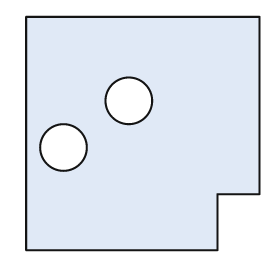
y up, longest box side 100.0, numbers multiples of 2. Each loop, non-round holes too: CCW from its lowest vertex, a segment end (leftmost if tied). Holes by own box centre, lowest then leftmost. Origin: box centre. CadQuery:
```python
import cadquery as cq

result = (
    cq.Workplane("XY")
    .moveTo(-50.0, -50.0)
    .lineTo(32.0, -50.0)
    .lineTo(32.0, -26.0)
    .lineTo(50.0, -26.0)
    .lineTo(50.0, 50.0)
    .lineTo(-50.0, 50.0)
    .close()
    .moveTo(-34.0, -6.0)
    .circle(10.0)
    .moveTo(-6.0, 14.0)
    .circle(10.0)
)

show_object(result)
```